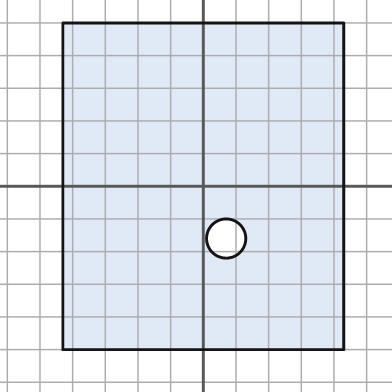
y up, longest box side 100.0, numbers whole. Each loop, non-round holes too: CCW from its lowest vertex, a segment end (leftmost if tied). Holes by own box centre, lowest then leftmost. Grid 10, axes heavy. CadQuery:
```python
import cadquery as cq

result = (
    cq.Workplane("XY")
    .moveTo(-43.0, -50.0)
    .lineTo(43.0, -50.0)
    .lineTo(43.0, 50.0)
    .lineTo(-43.0, 50.0)
    .close()
    .moveTo(7.0, -16.0)
    .circle(6.0)
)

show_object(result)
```